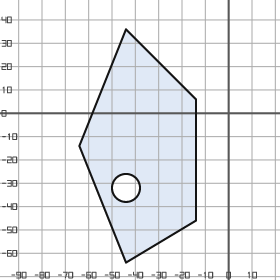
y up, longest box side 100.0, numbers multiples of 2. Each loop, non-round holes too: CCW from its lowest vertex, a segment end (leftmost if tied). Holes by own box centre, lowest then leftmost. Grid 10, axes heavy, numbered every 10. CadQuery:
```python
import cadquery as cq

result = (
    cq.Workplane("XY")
    .moveTo(-44.0, -64.0)
    .lineTo(-14.0, -46.0)
    .lineTo(-14.0, 6.0)
    .lineTo(-44.0, 36.0)
    .lineTo(-64.0, -14.0)
    .close()
    .moveTo(-44.0, -32.0)
    .circle(6.0)
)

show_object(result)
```